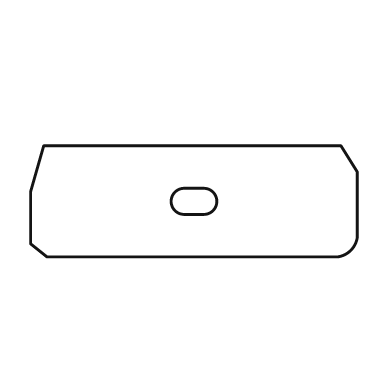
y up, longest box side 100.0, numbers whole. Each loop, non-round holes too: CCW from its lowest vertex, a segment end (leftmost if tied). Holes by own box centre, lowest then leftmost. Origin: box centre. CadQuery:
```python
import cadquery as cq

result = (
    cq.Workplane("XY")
    .moveTo(-45.0, -17.0)
    .lineTo(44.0, -17.0)
    .threePointArc((48.0, -15.0), (50.0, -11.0))
    .lineTo(50.0, 9.0)
    .lineTo(45.0, 17.0)
    .lineTo(-46.0, 17.0)
    .lineTo(-50.0, 3.0)
    .lineTo(-50.0, -13.0)
    .close()
    .moveTo(-3.0, -4.0)
    .lineTo(3.0, -4.0)
    .threePointArc((7.0, 0.0), (3.0, 4.0))
    .lineTo(-3.0, 4.0)
    .threePointArc((-7.0, 0.0), (-3.0, -4.0))
    .close()
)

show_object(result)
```